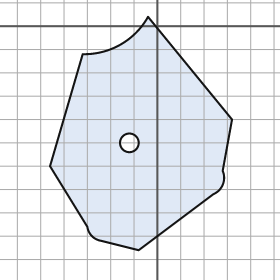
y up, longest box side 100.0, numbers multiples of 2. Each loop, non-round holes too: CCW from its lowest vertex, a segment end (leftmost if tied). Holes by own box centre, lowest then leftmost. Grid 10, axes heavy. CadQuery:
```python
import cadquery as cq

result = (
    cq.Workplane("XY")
    .moveTo(-8.0, -96.0)
    .lineTo(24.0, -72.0)
    .threePointArc((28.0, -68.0), (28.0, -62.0))
    .lineTo(32.0, -40.0)
    .lineTo(-4.0, 4.0)
    .threePointArc((-16.0, -8.0), (-32.0, -12.0))
    .lineTo(-46.0, -60.0)
    .lineTo(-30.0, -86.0)
    .threePointArc((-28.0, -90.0), (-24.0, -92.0))
    .close()
    .moveTo(-12.0, -50.0)
    .circle(4.0)
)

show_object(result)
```